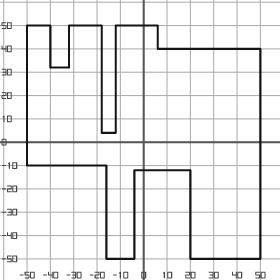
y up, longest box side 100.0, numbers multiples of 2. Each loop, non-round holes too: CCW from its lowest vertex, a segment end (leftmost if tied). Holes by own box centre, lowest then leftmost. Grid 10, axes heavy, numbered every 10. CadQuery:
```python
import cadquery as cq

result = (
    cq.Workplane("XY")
    .moveTo(-16.0, -50.0)
    .lineTo(-4.0, -50.0)
    .lineTo(-4.0, -12.0)
    .lineTo(20.0, -12.0)
    .lineTo(20.0, -50.0)
    .lineTo(50.0, -50.0)
    .lineTo(50.0, 40.0)
    .lineTo(6.0, 40.0)
    .lineTo(6.0, 50.0)
    .lineTo(-12.0, 50.0)
    .lineTo(-12.0, 4.0)
    .lineTo(-18.0, 4.0)
    .lineTo(-18.0, 50.0)
    .lineTo(-32.0, 50.0)
    .lineTo(-32.0, 32.0)
    .lineTo(-40.0, 32.0)
    .lineTo(-40.0, 50.0)
    .lineTo(-50.0, 50.0)
    .lineTo(-50.0, -10.0)
    .lineTo(-16.0, -10.0)
    .close()
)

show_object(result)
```